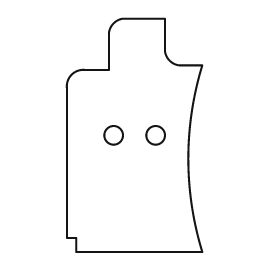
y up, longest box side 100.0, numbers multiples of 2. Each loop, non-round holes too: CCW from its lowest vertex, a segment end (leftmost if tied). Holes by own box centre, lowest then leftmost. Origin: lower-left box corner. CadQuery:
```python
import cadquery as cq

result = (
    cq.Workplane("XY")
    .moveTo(4.0, 0.0)
    .lineTo(58.0, 0.0)
    .threePointArc((52.0, 40.0), (58.0, 80.0))
    .lineTo(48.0, 80.0)
    .threePointArc((44.0, 82.0), (42.0, 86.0))
    .lineTo(42.0, 100.0)
    .lineTo(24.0, 100.0)
    .threePointArc((20.0, 98.0), (18.0, 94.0))
    .lineTo(18.0, 78.0)
    .lineTo(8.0, 78.0)
    .threePointArc((2.0, 76.0), (0.0, 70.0))
    .lineTo(0.0, 6.0)
    .lineTo(4.0, 6.0)
    .close()
    .moveTo(20.0, 50.0)
    .circle(4.0)
    .moveTo(38.0, 50.0)
    .circle(4.0)
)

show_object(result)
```